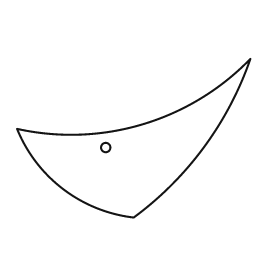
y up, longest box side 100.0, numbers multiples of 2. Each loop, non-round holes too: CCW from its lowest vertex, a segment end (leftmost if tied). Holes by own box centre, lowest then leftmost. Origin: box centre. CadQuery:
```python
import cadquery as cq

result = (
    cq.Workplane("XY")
    .moveTo(0.0, -34.0)
    .threePointArc((30.0, -4.0), (50.0, 34.0))
    .threePointArc((4.0, 6.0), (-50.0, 4.0))
    .threePointArc((-30.0, -22.0), (0.0, -34.0))
    .close()
    .moveTo(-12.0, -4.0)
    .circle(2.0)
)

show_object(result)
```